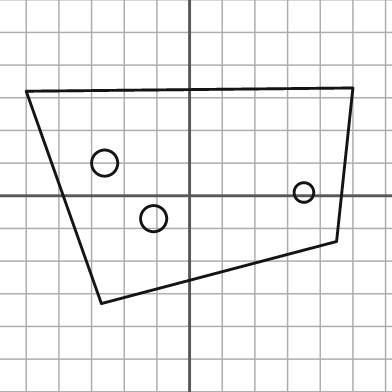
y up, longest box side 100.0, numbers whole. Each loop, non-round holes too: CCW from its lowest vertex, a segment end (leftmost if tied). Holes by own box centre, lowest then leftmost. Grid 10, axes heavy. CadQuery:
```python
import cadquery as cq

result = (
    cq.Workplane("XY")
    .moveTo(-27.0, -33.0)
    .lineTo(45.0, -14.0)
    .lineTo(50.0, 33.0)
    .lineTo(-50.0, 32.0)
    .close()
    .moveTo(-11.0, -7.0)
    .circle(4.0)
    .moveTo(35.0, 1.0)
    .circle(3.0)
    .moveTo(-26.0, 10.0)
    .circle(4.0)
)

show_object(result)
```